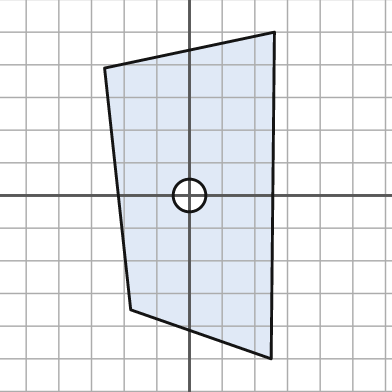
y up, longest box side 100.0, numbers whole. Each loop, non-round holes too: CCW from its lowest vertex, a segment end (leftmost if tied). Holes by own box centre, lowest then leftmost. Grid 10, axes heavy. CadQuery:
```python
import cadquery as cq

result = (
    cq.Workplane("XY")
    .moveTo(25.0, -50.0)
    .lineTo(26.0, 50.0)
    .lineTo(-26.0, 39.0)
    .lineTo(-18.0, -35.0)
    .close()
    .moveTo(0.0, 0.0)
    .circle(5.0)
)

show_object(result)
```